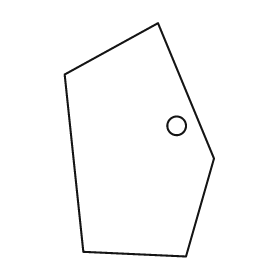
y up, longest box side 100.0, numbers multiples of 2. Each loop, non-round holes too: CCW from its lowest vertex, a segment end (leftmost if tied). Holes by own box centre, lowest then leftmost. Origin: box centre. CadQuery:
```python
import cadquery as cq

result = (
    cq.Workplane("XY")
    .moveTo(20.0, -50.0)
    .lineTo(32.0, -8.0)
    .lineTo(8.0, 50.0)
    .lineTo(-32.0, 28.0)
    .lineTo(-24.0, -48.0)
    .close()
    .moveTo(16.0, 6.0)
    .circle(4.0)
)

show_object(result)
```